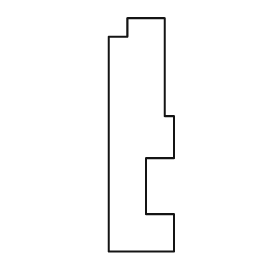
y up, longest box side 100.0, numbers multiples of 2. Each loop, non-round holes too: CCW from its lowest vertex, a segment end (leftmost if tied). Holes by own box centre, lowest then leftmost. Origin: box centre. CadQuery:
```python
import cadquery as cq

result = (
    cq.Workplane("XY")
    .moveTo(-14.0, -50.0)
    .lineTo(14.0, -50.0)
    .lineTo(14.0, -34.0)
    .lineTo(2.0, -34.0)
    .lineTo(2.0, -10.0)
    .lineTo(14.0, -10.0)
    .lineTo(14.0, 8.0)
    .lineTo(10.0, 8.0)
    .lineTo(10.0, 50.0)
    .lineTo(-6.0, 50.0)
    .lineTo(-6.0, 42.0)
    .lineTo(-14.0, 42.0)
    .close()
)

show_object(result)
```